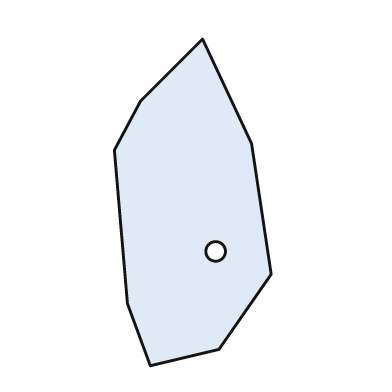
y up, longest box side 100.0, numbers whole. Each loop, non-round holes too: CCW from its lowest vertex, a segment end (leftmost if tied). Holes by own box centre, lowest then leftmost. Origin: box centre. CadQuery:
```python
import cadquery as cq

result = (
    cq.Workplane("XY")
    .moveTo(-13.0, -50.0)
    .lineTo(8.0, -45.0)
    .lineTo(24.0, -22.0)
    .lineTo(18.0, 18.0)
    .lineTo(3.0, 50.0)
    .lineTo(-16.0, 31.0)
    .lineTo(-24.0, 16.0)
    .lineTo(-20.0, -31.0)
    .close()
    .moveTo(7.0, -15.0)
    .circle(3.0)
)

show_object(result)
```